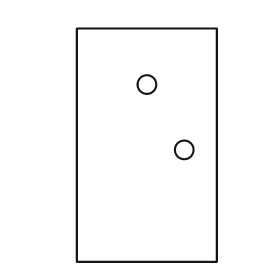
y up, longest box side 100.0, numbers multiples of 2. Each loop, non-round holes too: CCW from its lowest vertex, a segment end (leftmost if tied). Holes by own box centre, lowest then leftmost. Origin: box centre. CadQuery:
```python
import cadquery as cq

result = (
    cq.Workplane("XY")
    .moveTo(-30.0, -50.0)
    .lineTo(30.0, -50.0)
    .lineTo(30.0, 50.0)
    .lineTo(-30.0, 50.0)
    .close()
    .moveTo(16.0, -2.0)
    .circle(4.0)
    .moveTo(0.0, 26.0)
    .circle(4.0)
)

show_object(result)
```